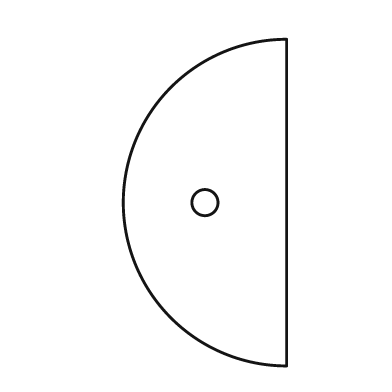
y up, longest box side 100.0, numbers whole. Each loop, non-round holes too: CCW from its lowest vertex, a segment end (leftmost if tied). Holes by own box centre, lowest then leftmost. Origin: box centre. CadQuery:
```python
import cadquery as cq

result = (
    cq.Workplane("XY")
    .moveTo(25.0, -50.0)
    .lineTo(25.0, 50.0)
    .threePointArc((-25.0, 0.0), (25.0, -50.0))
    .close()
    .moveTo(0.0, 0.0)
    .circle(4.0)
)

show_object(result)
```